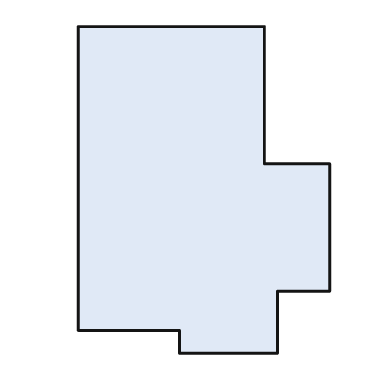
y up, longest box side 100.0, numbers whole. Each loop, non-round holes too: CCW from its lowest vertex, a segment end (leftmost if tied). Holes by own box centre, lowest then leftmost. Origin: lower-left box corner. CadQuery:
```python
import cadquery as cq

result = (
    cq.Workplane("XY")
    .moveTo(31.0, 0.0)
    .lineTo(61.0, 0.0)
    .lineTo(61.0, 19.0)
    .lineTo(77.0, 19.0)
    .lineTo(77.0, 58.0)
    .lineTo(57.0, 58.0)
    .lineTo(57.0, 100.0)
    .lineTo(0.0, 100.0)
    .lineTo(0.0, 7.0)
    .lineTo(31.0, 7.0)
    .close()
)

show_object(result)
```